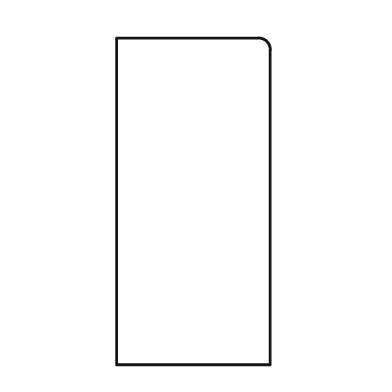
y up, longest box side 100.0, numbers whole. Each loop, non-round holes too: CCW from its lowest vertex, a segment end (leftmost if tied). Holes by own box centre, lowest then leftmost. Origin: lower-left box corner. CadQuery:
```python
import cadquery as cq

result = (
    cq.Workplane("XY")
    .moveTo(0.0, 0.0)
    .lineTo(47.0, 0.0)
    .lineTo(47.0, 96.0)
    .threePointArc((46.0, 99.0), (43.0, 100.0))
    .lineTo(0.0, 100.0)
    .close()
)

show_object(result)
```